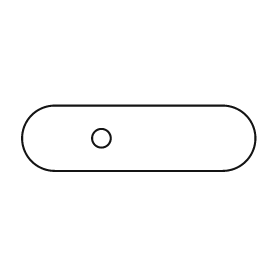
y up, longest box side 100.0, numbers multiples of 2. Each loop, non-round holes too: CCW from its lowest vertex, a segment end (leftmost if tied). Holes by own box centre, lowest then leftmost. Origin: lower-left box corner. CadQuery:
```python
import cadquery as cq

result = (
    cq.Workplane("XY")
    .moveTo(14.0, 0.0)
    .lineTo(86.0, 0.0)
    .threePointArc((100.0, 14.0), (86.0, 28.0))
    .lineTo(14.0, 28.0)
    .threePointArc((0.0, 14.0), (14.0, 0.0))
    .close()
    .moveTo(34.0, 14.0)
    .circle(4.0)
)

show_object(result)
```